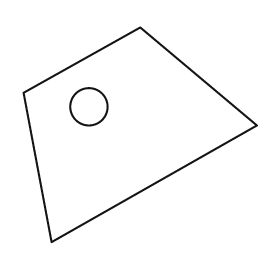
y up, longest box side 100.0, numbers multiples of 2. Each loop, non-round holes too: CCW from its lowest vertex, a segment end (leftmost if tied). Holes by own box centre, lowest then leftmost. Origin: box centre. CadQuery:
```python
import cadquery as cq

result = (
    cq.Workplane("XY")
    .moveTo(-38.0, -46.0)
    .lineTo(50.0, 4.0)
    .lineTo(0.0, 46.0)
    .lineTo(-50.0, 18.0)
    .close()
    .moveTo(-22.0, 12.0)
    .circle(8.0)
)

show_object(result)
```